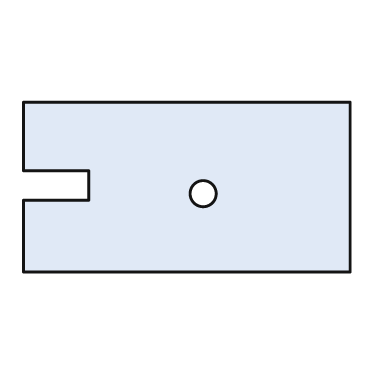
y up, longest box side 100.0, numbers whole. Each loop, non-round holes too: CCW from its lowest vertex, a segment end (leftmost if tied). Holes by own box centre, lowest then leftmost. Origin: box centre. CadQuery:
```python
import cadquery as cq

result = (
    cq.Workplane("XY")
    .moveTo(-50.0, -26.0)
    .lineTo(50.0, -26.0)
    .lineTo(50.0, 26.0)
    .lineTo(-50.0, 26.0)
    .lineTo(-50.0, 5.0)
    .lineTo(-30.0, 5.0)
    .lineTo(-30.0, -4.0)
    .lineTo(-50.0, -4.0)
    .close()
    .moveTo(5.0, -2.0)
    .circle(4.0)
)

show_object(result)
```